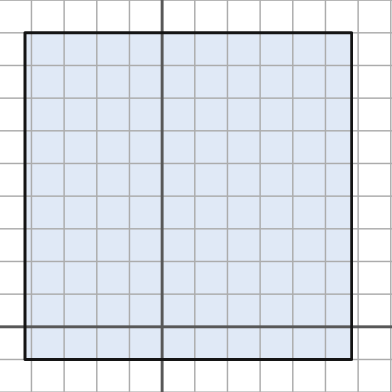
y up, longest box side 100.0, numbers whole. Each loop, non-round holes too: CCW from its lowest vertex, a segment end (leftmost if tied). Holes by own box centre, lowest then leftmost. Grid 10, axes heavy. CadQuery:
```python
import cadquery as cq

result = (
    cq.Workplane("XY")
    .moveTo(-42.0, -10.0)
    .lineTo(58.0, -10.0)
    .lineTo(58.0, 90.0)
    .lineTo(-42.0, 90.0)
    .close()
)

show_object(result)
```